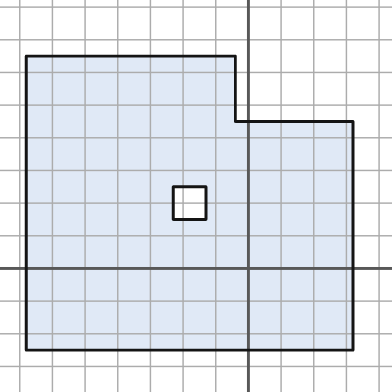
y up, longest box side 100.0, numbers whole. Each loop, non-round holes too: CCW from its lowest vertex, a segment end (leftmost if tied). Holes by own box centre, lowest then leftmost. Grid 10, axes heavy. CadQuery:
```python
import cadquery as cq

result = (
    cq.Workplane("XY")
    .moveTo(-68.0, -25.0)
    .lineTo(32.0, -25.0)
    .lineTo(32.0, 45.0)
    .lineTo(-4.0, 45.0)
    .lineTo(-4.0, 65.0)
    .lineTo(-68.0, 65.0)
    .close()
    .moveTo(-23.0, 15.0)
    .lineTo(-13.0, 15.0)
    .lineTo(-13.0, 25.0)
    .lineTo(-23.0, 25.0)
    .close()
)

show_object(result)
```